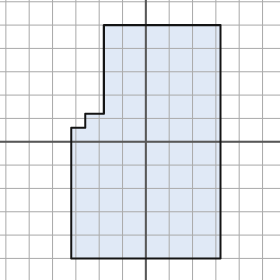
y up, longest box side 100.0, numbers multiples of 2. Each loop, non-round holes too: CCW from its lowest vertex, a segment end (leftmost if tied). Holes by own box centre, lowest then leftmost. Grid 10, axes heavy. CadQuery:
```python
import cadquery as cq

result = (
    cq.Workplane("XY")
    .moveTo(-32.0, -50.0)
    .lineTo(32.0, -50.0)
    .lineTo(32.0, 50.0)
    .lineTo(-18.0, 50.0)
    .lineTo(-18.0, 12.0)
    .lineTo(-26.0, 12.0)
    .lineTo(-26.0, 6.0)
    .lineTo(-32.0, 6.0)
    .close()
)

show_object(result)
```